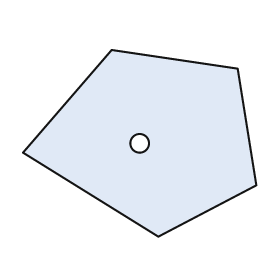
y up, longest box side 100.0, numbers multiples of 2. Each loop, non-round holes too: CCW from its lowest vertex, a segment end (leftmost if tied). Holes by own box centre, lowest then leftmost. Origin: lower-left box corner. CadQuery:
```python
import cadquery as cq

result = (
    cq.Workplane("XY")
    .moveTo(58.0, 0.0)
    .lineTo(100.0, 22.0)
    .lineTo(92.0, 72.0)
    .lineTo(38.0, 80.0)
    .lineTo(0.0, 36.0)
    .close()
    .moveTo(50.0, 40.0)
    .circle(4.0)
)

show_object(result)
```